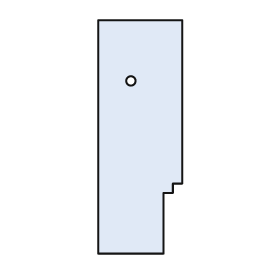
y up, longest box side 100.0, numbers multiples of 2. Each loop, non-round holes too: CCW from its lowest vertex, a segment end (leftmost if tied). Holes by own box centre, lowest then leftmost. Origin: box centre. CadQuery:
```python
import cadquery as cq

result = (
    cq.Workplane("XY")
    .moveTo(-18.0, -50.0)
    .lineTo(10.0, -50.0)
    .lineTo(10.0, -24.0)
    .lineTo(14.0, -24.0)
    .lineTo(14.0, -20.0)
    .lineTo(18.0, -20.0)
    .lineTo(18.0, 50.0)
    .lineTo(-18.0, 50.0)
    .close()
    .moveTo(-4.0, 24.0)
    .circle(2.0)
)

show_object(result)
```